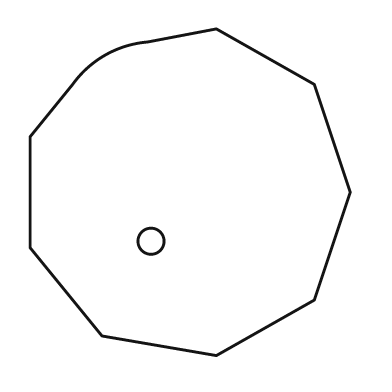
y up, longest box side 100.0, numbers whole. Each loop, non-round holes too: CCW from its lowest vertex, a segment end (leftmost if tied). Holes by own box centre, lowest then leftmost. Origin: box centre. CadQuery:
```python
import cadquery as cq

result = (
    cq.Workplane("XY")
    .moveTo(8.0, -50.0)
    .lineTo(38.0, -33.0)
    .lineTo(49.0, 0.0)
    .lineTo(38.0, 33.0)
    .lineTo(8.0, 50.0)
    .lineTo(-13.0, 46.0)
    .threePointArc((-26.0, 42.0), (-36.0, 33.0))
    .lineTo(-49.0, 17.0)
    .lineTo(-49.0, -17.0)
    .lineTo(-27.0, -44.0)
    .close()
    .moveTo(-12.0, -15.0)
    .circle(4.0)
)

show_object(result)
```